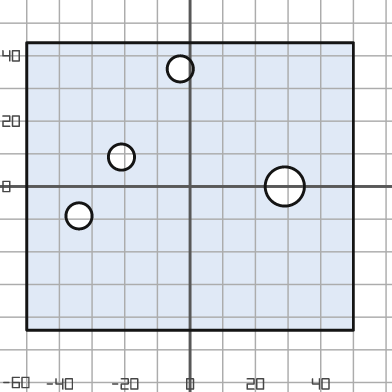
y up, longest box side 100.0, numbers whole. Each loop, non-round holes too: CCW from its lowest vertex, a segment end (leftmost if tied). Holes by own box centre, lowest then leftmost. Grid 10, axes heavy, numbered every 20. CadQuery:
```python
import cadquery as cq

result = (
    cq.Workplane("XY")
    .moveTo(-50.0, -44.0)
    .lineTo(50.0, -44.0)
    .lineTo(50.0, 44.0)
    .lineTo(-50.0, 44.0)
    .close()
    .moveTo(-34.0, -9.0)
    .circle(4.0)
    .moveTo(29.0, 0.0)
    .circle(6.0)
    .moveTo(-21.0, 9.0)
    .circle(4.0)
    .moveTo(-3.0, 36.0)
    .circle(4.0)
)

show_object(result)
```